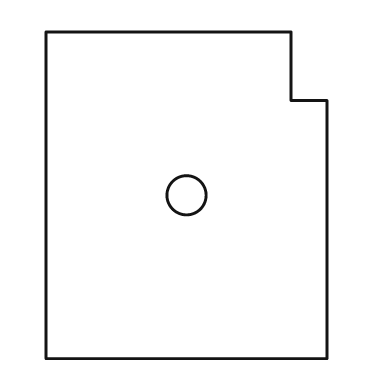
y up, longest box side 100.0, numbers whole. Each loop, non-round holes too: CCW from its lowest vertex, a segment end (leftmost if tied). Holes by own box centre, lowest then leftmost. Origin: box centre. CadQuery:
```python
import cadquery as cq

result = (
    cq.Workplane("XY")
    .moveTo(-43.0, -50.0)
    .lineTo(43.0, -50.0)
    .lineTo(43.0, 29.0)
    .lineTo(32.0, 29.0)
    .lineTo(32.0, 50.0)
    .lineTo(-43.0, 50.0)
    .close()
    .moveTo(0.0, 0.0)
    .circle(6.0)
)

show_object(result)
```